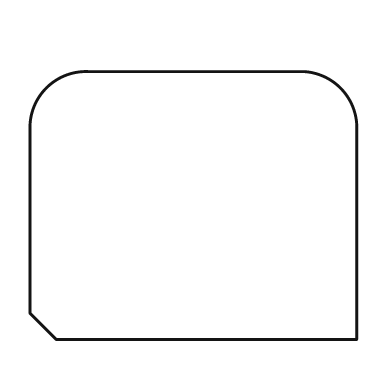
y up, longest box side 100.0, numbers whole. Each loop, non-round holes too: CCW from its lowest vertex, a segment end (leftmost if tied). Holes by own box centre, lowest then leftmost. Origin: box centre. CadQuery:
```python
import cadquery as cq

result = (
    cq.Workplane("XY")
    .moveTo(-42.0, -41.0)
    .lineTo(50.0, -41.0)
    .lineTo(50.0, 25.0)
    .threePointArc((45.0, 36.0), (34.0, 41.0))
    .lineTo(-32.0, 41.0)
    .threePointArc((-45.0, 36.0), (-50.0, 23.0))
    .lineTo(-50.0, -33.0)
    .close()
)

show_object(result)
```